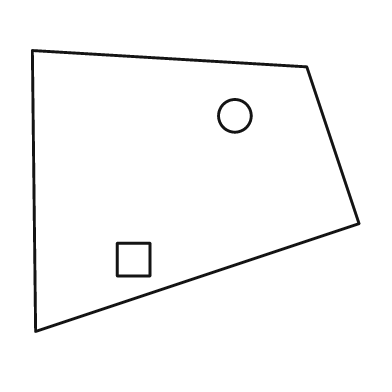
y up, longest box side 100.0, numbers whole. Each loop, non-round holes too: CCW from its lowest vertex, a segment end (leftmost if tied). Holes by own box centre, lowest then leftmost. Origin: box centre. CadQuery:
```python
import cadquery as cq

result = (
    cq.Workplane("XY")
    .moveTo(-49.0, -43.0)
    .lineTo(50.0, -10.0)
    .lineTo(34.0, 38.0)
    .lineTo(-50.0, 43.0)
    .close()
    .moveTo(-24.0, -26.0)
    .lineTo(-14.0, -26.0)
    .lineTo(-14.0, -16.0)
    .lineTo(-24.0, -16.0)
    .close()
    .moveTo(12.0, 23.0)
    .circle(5.0)
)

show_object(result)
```